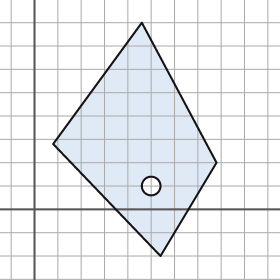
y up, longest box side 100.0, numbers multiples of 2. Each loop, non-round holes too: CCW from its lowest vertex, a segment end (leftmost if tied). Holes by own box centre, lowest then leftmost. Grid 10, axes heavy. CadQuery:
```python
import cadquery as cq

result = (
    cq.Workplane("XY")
    .moveTo(54.0, -20.0)
    .lineTo(78.0, 20.0)
    .lineTo(46.0, 80.0)
    .lineTo(8.0, 28.0)
    .close()
    .moveTo(50.0, 10.0)
    .circle(4.0)
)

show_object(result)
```